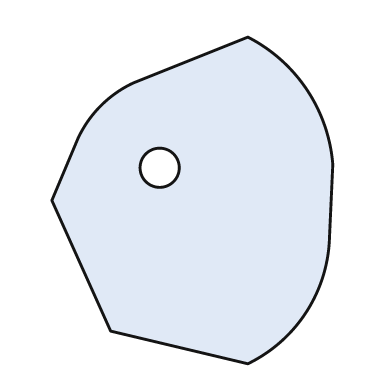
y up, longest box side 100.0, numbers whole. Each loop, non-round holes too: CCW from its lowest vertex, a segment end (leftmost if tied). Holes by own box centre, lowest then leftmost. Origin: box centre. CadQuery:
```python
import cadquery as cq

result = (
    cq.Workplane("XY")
    .moveTo(17.0, -50.0)
    .threePointArc((35.0, -34.0), (42.0, -11.0))
    .lineTo(43.0, 11.0)
    .threePointArc((35.0, 34.0), (17.0, 50.0))
    .lineTo(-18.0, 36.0)
    .threePointArc((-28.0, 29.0), (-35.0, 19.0))
    .lineTo(-43.0, 0.0)
    .lineTo(-25.0, -40.0)
    .close()
    .moveTo(-10.0, 10.0)
    .circle(6.0)
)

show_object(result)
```